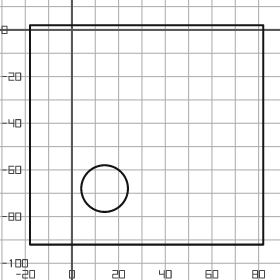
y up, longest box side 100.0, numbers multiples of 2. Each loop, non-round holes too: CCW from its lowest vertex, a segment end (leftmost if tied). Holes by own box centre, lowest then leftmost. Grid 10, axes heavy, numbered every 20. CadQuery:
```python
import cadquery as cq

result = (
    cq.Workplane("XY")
    .moveTo(-18.0, -92.0)
    .lineTo(82.0, -92.0)
    .lineTo(82.0, 2.0)
    .lineTo(-18.0, 2.0)
    .close()
    .moveTo(14.0, -68.0)
    .circle(10.0)
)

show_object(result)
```